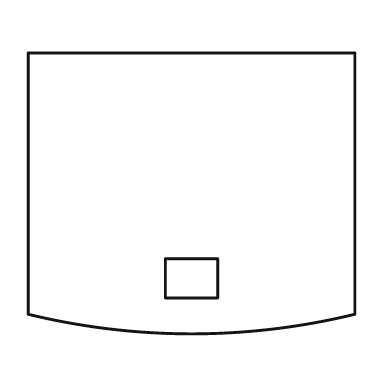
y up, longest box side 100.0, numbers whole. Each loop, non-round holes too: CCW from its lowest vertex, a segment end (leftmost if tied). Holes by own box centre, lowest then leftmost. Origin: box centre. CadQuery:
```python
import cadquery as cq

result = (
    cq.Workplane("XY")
    .moveTo(-50.0, -37.0)
    .threePointArc((0.0, -43.0), (50.0, -37.0))
    .lineTo(50.0, 43.0)
    .lineTo(-50.0, 43.0)
    .close()
    .moveTo(-8.0, -32.0)
    .lineTo(8.0, -32.0)
    .lineTo(8.0, -20.0)
    .lineTo(-8.0, -20.0)
    .close()
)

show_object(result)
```